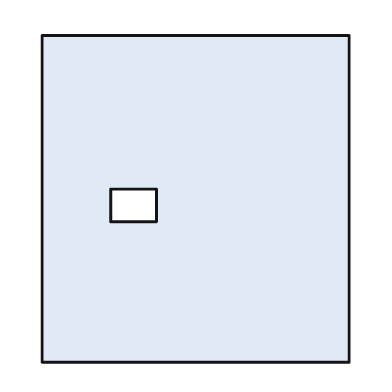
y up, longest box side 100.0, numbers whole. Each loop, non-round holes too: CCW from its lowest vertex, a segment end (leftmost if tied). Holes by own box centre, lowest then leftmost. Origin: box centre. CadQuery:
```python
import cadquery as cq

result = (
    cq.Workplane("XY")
    .moveTo(-47.0, -50.0)
    .lineTo(47.0, -50.0)
    .lineTo(47.0, 50.0)
    .lineTo(-47.0, 50.0)
    .close()
    .moveTo(-26.0, -7.0)
    .lineTo(-12.0, -7.0)
    .lineTo(-12.0, 3.0)
    .lineTo(-26.0, 3.0)
    .close()
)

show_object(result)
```